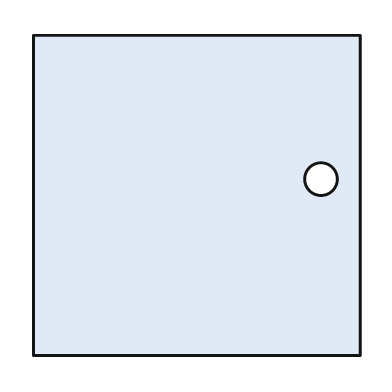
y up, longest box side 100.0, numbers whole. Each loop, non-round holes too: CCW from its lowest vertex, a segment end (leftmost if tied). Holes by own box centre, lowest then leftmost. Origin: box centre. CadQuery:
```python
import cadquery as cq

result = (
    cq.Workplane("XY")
    .moveTo(-50.0, -49.0)
    .lineTo(50.0, -49.0)
    .lineTo(50.0, 49.0)
    .lineTo(-50.0, 49.0)
    .close()
    .moveTo(38.0, 5.0)
    .circle(5.0)
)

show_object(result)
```